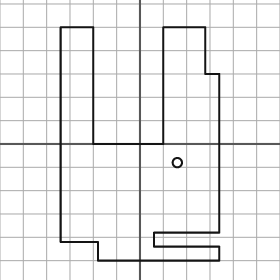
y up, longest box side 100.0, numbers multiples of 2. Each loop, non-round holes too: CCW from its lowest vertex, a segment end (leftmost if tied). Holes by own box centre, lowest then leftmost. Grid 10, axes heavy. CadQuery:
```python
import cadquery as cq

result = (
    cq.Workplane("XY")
    .moveTo(-18.0, -50.0)
    .lineTo(34.0, -50.0)
    .lineTo(34.0, -44.0)
    .lineTo(6.0, -44.0)
    .lineTo(6.0, -38.0)
    .lineTo(34.0, -38.0)
    .lineTo(34.0, 30.0)
    .lineTo(28.0, 30.0)
    .lineTo(28.0, 50.0)
    .lineTo(10.0, 50.0)
    .lineTo(10.0, 0.0)
    .lineTo(-20.0, 0.0)
    .lineTo(-20.0, 50.0)
    .lineTo(-34.0, 50.0)
    .lineTo(-34.0, -42.0)
    .lineTo(-18.0, -42.0)
    .close()
    .moveTo(16.0, -8.0)
    .circle(2.0)
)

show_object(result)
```